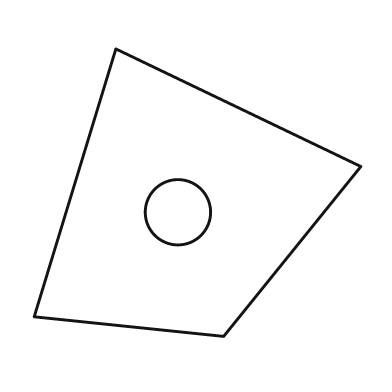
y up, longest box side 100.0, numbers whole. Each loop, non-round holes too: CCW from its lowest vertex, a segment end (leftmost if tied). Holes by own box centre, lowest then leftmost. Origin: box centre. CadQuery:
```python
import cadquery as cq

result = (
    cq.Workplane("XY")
    .moveTo(8.0, -44.0)
    .lineTo(50.0, 8.0)
    .lineTo(-25.0, 44.0)
    .lineTo(-50.0, -38.0)
    .close()
    .moveTo(-6.0, -6.0)
    .circle(10.0)
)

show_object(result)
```